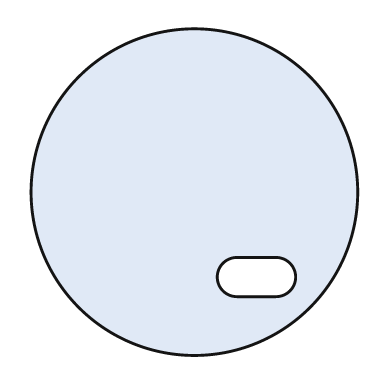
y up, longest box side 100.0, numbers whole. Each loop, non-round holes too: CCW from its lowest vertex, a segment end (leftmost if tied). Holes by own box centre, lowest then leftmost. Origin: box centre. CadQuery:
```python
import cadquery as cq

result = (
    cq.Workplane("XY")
    .moveTo(0.0, 0.0)
    .circle(50.0)
    .moveTo(13.0, -32.0)
    .lineTo(25.0, -32.0)
    .threePointArc((31.0, -26.0), (25.0, -20.0))
    .lineTo(13.0, -20.0)
    .threePointArc((7.0, -26.0), (13.0, -32.0))
    .close()
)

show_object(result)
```